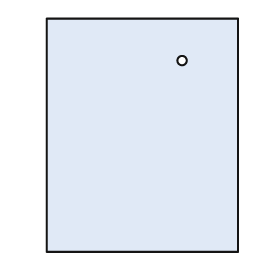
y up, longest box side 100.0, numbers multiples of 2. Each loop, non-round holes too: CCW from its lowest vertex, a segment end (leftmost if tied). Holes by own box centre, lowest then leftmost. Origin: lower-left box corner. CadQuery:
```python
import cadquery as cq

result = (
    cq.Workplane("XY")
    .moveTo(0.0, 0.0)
    .lineTo(82.0, 0.0)
    .lineTo(82.0, 100.0)
    .lineTo(0.0, 100.0)
    .close()
    .moveTo(58.0, 82.0)
    .circle(2.0)
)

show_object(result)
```